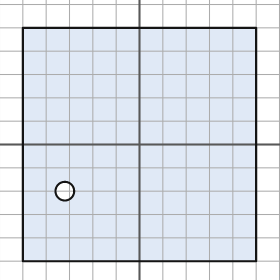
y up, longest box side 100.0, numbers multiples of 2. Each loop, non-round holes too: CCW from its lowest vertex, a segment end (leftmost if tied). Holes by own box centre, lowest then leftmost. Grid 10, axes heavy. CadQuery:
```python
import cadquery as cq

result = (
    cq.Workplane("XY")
    .moveTo(-50.0, -50.0)
    .lineTo(50.0, -50.0)
    .lineTo(50.0, 50.0)
    .lineTo(-50.0, 50.0)
    .close()
    .moveTo(-32.0, -20.0)
    .circle(4.0)
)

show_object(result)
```